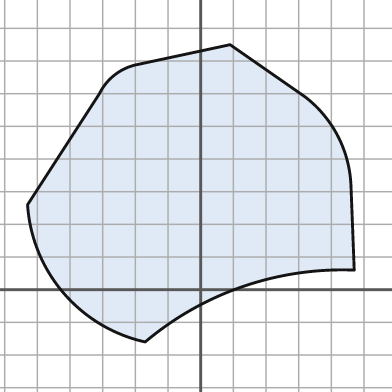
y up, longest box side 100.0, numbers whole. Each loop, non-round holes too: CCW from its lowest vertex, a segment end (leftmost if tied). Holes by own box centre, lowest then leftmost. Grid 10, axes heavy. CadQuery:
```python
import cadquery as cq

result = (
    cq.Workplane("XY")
    .moveTo(-17.0, -16.0)
    .threePointArc((13.0, 1.0), (47.0, 6.0))
    .lineTo(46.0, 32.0)
    .threePointArc((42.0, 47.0), (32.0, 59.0))
    .lineTo(9.0, 75.0)
    .lineTo(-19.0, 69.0)
    .threePointArc((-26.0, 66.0), (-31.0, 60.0))
    .lineTo(-53.0, 26.0)
    .threePointArc((-42.0, -1.0), (-17.0, -16.0))
    .close()
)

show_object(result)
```